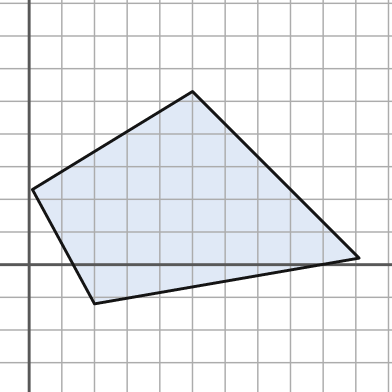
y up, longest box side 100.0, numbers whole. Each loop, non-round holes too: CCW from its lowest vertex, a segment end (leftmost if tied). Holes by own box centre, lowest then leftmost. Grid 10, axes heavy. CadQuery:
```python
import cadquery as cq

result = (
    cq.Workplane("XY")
    .moveTo(20.0, -12.0)
    .lineTo(101.0, 2.0)
    .lineTo(50.0, 53.0)
    .lineTo(1.0, 23.0)
    .close()
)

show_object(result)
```